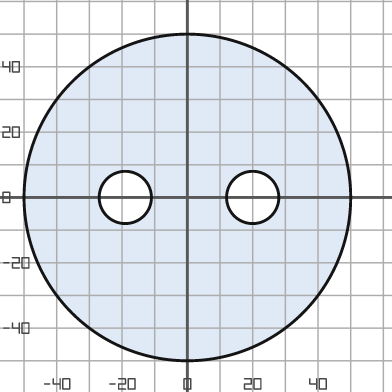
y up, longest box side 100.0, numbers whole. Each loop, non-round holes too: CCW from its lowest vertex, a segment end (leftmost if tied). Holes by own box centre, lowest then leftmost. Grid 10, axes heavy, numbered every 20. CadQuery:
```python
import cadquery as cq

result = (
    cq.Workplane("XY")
    .moveTo(0.0, 0.0)
    .circle(50.0)
    .moveTo(-19.0, 0.0)
    .circle(8.0)
    .moveTo(20.0, 0.0)
    .circle(8.0)
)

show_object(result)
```